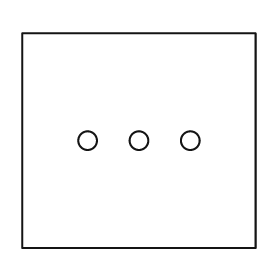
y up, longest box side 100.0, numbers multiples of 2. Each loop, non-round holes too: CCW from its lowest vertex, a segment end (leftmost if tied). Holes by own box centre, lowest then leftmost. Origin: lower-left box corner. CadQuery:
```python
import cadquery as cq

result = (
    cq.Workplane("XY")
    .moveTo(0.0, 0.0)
    .lineTo(100.0, 0.0)
    .lineTo(100.0, 92.0)
    .lineTo(0.0, 92.0)
    .close()
    .moveTo(28.0, 46.0)
    .circle(4.0)
    .moveTo(50.0, 46.0)
    .circle(4.0)
    .moveTo(72.0, 46.0)
    .circle(4.0)
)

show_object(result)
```